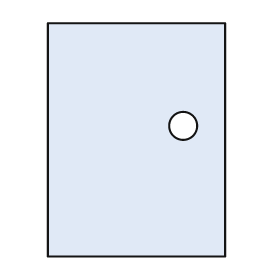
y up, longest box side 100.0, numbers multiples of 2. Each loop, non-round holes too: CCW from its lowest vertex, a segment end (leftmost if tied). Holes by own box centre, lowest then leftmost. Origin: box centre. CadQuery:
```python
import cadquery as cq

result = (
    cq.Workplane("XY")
    .moveTo(-38.0, -50.0)
    .lineTo(38.0, -50.0)
    .lineTo(38.0, 50.0)
    .lineTo(-38.0, 50.0)
    .close()
    .moveTo(20.0, 6.0)
    .circle(6.0)
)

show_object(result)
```